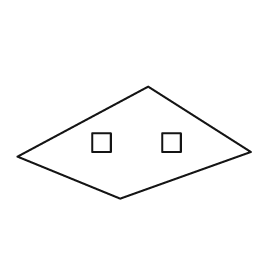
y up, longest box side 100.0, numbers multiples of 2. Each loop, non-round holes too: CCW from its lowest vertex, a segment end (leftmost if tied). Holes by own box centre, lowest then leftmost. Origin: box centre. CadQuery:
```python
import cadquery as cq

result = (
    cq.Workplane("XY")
    .moveTo(-6.0, -24.0)
    .lineTo(50.0, -4.0)
    .lineTo(6.0, 24.0)
    .lineTo(-50.0, -6.0)
    .close()
    .moveTo(-18.0, -4.0)
    .lineTo(-10.0, -4.0)
    .lineTo(-10.0, 4.0)
    .lineTo(-18.0, 4.0)
    .close()
    .moveTo(12.0, -4.0)
    .lineTo(20.0, -4.0)
    .lineTo(20.0, 4.0)
    .lineTo(12.0, 4.0)
    .close()
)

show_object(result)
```